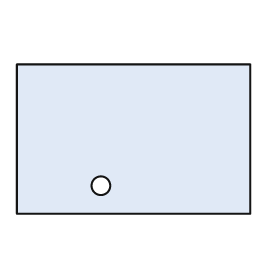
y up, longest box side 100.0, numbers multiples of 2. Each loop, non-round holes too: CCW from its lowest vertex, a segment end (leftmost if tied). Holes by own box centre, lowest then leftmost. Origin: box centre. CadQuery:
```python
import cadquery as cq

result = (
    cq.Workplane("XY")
    .moveTo(-50.0, -32.0)
    .lineTo(50.0, -32.0)
    .lineTo(50.0, 32.0)
    .lineTo(-50.0, 32.0)
    .close()
    .moveTo(-14.0, -20.0)
    .circle(4.0)
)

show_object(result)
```